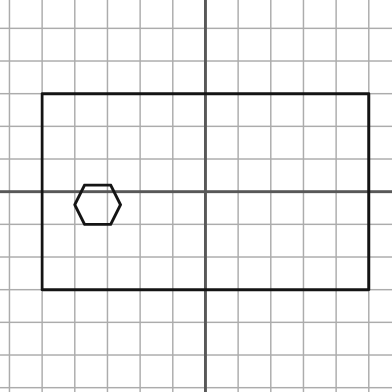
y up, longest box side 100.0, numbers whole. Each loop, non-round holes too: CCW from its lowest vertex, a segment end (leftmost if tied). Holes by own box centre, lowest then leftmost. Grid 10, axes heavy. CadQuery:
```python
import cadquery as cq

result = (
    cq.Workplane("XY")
    .moveTo(-50.0, -30.0)
    .lineTo(50.0, -30.0)
    .lineTo(50.0, 30.0)
    .lineTo(-50.0, 30.0)
    .close()
    .moveTo(-37.0, -10.0)
    .lineTo(-29.0, -10.0)
    .lineTo(-26.0, -4.0)
    .lineTo(-29.0, 2.0)
    .lineTo(-37.0, 2.0)
    .lineTo(-40.0, -4.0)
    .close()
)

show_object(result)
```